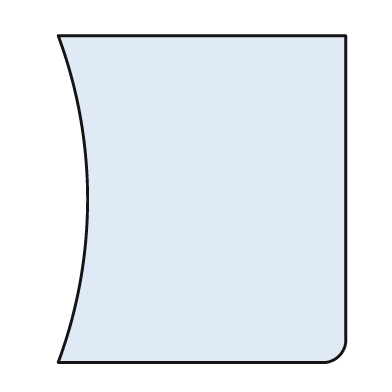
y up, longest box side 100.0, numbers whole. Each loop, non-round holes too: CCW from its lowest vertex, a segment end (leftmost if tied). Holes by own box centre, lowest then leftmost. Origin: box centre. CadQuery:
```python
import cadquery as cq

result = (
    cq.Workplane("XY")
    .moveTo(-44.0, -50.0)
    .lineTo(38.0, -50.0)
    .threePointArc((42.0, -48.0), (44.0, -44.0))
    .lineTo(44.0, 50.0)
    .lineTo(-44.0, 50.0)
    .threePointArc((-35.0, 0.0), (-44.0, -50.0))
    .close()
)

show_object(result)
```